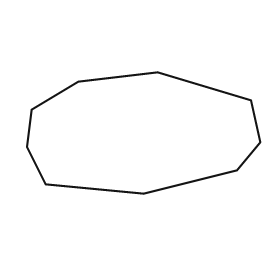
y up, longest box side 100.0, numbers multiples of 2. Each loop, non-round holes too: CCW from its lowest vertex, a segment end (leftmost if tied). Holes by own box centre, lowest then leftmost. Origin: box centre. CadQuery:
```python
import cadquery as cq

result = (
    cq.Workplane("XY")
    .moveTo(0.0, -26.0)
    .lineTo(40.0, -16.0)
    .lineTo(50.0, -4.0)
    .lineTo(46.0, 14.0)
    .lineTo(6.0, 26.0)
    .lineTo(-28.0, 22.0)
    .lineTo(-48.0, 10.0)
    .lineTo(-50.0, -6.0)
    .lineTo(-42.0, -22.0)
    .close()
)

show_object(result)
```